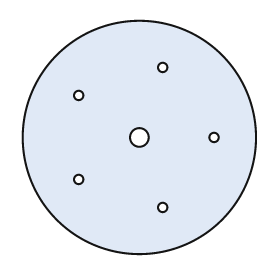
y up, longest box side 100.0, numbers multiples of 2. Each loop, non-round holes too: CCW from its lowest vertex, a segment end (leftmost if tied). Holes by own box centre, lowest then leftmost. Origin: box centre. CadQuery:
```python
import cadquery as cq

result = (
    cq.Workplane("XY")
    .moveTo(0.0, 0.0)
    .circle(50.0)
    .moveTo(10.0, -30.0)
    .circle(2.0)
    .moveTo(-26.0, -18.0)
    .circle(2.0)
    .moveTo(0.0, 0.0)
    .circle(4.0)
    .moveTo(32.0, 0.0)
    .circle(2.0)
    .moveTo(-26.0, 18.0)
    .circle(2.0)
    .moveTo(10.0, 30.0)
    .circle(2.0)
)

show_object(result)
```